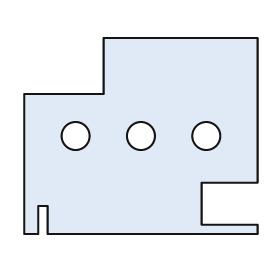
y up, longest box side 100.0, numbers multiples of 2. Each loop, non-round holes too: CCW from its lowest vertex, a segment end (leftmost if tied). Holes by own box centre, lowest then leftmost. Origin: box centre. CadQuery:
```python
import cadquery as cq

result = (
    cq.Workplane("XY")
    .moveTo(-50.0, -42.0)
    .lineTo(-44.0, -42.0)
    .lineTo(-44.0, -30.0)
    .lineTo(-40.0, -30.0)
    .lineTo(-40.0, -42.0)
    .lineTo(50.0, -42.0)
    .lineTo(50.0, -38.0)
    .lineTo(26.0, -38.0)
    .lineTo(26.0, -20.0)
    .lineTo(50.0, -20.0)
    .lineTo(50.0, 42.0)
    .lineTo(-16.0, 42.0)
    .lineTo(-16.0, 18.0)
    .lineTo(-50.0, 18.0)
    .close()
    .moveTo(-28.0, 0.0)
    .circle(6.0)
    .moveTo(0.0, 0.0)
    .circle(6.0)
    .moveTo(28.0, 0.0)
    .circle(6.0)
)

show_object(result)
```